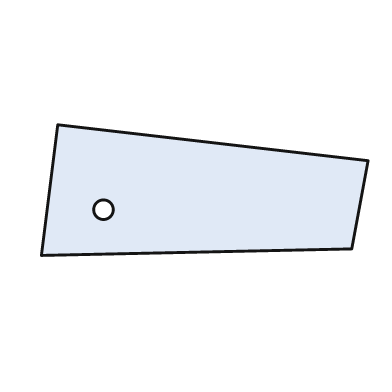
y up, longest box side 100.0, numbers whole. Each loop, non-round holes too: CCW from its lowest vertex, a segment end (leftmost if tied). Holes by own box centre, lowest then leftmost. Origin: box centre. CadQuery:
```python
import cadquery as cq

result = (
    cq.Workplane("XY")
    .moveTo(-50.0, -20.0)
    .lineTo(45.0, -18.0)
    .lineTo(50.0, 9.0)
    .lineTo(-45.0, 20.0)
    .close()
    .moveTo(-31.0, -6.0)
    .circle(3.0)
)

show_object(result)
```